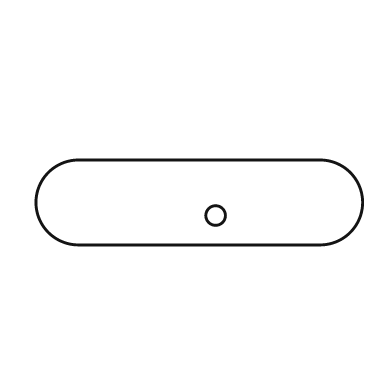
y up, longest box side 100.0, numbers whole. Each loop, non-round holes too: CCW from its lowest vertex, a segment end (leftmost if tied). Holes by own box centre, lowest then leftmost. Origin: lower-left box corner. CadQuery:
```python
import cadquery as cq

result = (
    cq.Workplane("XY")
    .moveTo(13.0, 0.0)
    .lineTo(87.0, 0.0)
    .threePointArc((100.0, 13.0), (87.0, 26.0))
    .lineTo(13.0, 26.0)
    .threePointArc((0.0, 13.0), (13.0, 0.0))
    .close()
    .moveTo(55.0, 9.0)
    .circle(3.0)
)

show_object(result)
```